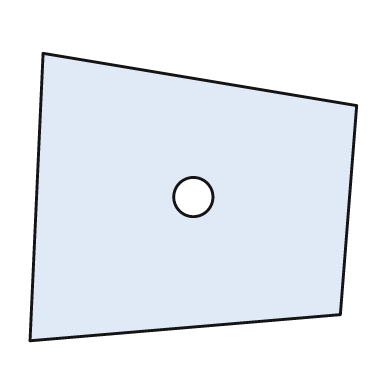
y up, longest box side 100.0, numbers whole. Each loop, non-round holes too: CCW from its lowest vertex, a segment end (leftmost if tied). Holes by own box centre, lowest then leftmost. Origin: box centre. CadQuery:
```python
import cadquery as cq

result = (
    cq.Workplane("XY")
    .moveTo(-50.0, -44.0)
    .lineTo(45.0, -36.0)
    .lineTo(50.0, 28.0)
    .lineTo(-46.0, 44.0)
    .close()
    .moveTo(0.0, 0.0)
    .circle(6.0)
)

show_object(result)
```